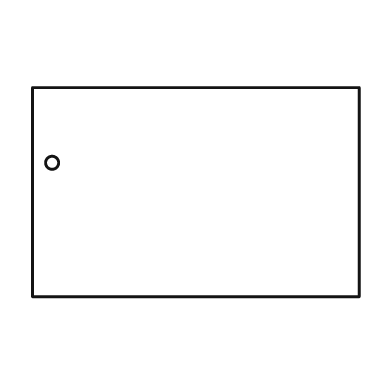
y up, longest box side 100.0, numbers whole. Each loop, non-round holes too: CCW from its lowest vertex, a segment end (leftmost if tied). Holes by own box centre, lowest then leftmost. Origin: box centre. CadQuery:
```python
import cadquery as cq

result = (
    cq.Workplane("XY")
    .moveTo(-50.0, -32.0)
    .lineTo(50.0, -32.0)
    .lineTo(50.0, 32.0)
    .lineTo(-50.0, 32.0)
    .close()
    .moveTo(-44.0, 9.0)
    .circle(2.0)
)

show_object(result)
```